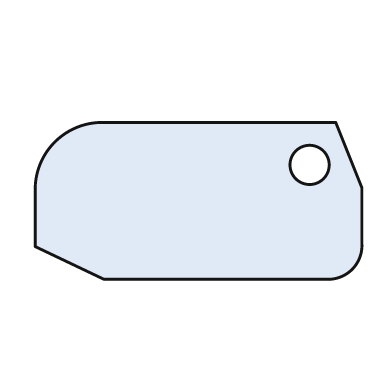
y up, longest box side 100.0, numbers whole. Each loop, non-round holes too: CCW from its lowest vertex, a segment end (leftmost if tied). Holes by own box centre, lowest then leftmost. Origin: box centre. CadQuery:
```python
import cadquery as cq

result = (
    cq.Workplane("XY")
    .moveTo(-29.0, -24.0)
    .lineTo(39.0, -24.0)
    .threePointArc((47.0, -21.0), (50.0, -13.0))
    .lineTo(50.0, 4.0)
    .lineTo(42.0, 24.0)
    .lineTo(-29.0, 24.0)
    .threePointArc((-44.0, 18.0), (-50.0, 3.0))
    .lineTo(-50.0, -14.0)
    .close()
    .moveTo(34.0, 11.0)
    .circle(6.0)
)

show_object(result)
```